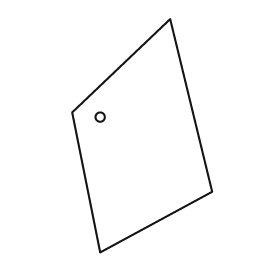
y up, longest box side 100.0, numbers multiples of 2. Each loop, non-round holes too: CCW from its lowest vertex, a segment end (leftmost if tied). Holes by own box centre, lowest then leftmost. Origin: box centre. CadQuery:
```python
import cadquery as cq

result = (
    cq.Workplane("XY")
    .moveTo(-18.0, -50.0)
    .lineTo(30.0, -24.0)
    .lineTo(12.0, 50.0)
    .lineTo(-30.0, 10.0)
    .close()
    .moveTo(-18.0, 8.0)
    .circle(2.0)
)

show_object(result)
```